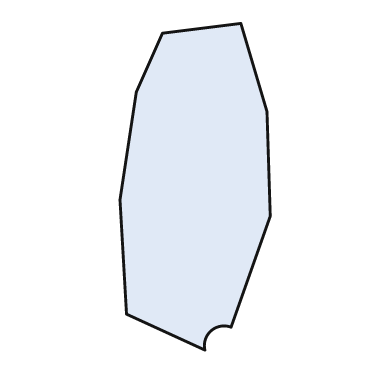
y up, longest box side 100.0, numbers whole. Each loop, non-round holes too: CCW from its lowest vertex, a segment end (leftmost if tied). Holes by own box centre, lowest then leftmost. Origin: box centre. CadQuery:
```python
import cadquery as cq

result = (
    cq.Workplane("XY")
    .moveTo(3.0, -50.0)
    .threePointArc((5.0, -44.0), (11.0, -43.0))
    .lineTo(23.0, -9.0)
    .lineTo(22.0, 23.0)
    .lineTo(14.0, 50.0)
    .lineTo(-10.0, 47.0)
    .lineTo(-18.0, 29.0)
    .lineTo(-23.0, -4.0)
    .lineTo(-21.0, -39.0)
    .close()
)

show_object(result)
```